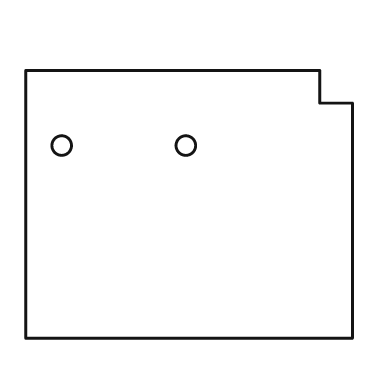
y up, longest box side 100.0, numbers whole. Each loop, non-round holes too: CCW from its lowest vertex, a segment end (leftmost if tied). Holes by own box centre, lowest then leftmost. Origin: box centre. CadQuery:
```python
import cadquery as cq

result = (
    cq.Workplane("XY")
    .moveTo(-50.0, -41.0)
    .lineTo(50.0, -41.0)
    .lineTo(50.0, 31.0)
    .lineTo(40.0, 31.0)
    .lineTo(40.0, 41.0)
    .lineTo(-50.0, 41.0)
    .close()
    .moveTo(-39.0, 18.0)
    .circle(3.0)
    .moveTo(-1.0, 18.0)
    .circle(3.0)
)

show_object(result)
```